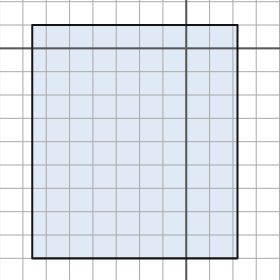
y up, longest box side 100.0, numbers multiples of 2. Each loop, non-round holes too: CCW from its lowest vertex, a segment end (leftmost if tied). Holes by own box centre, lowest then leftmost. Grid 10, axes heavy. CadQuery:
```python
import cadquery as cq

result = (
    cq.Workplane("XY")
    .moveTo(-66.0, -90.0)
    .lineTo(22.0, -90.0)
    .lineTo(22.0, 10.0)
    .lineTo(-66.0, 10.0)
    .close()
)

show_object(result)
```